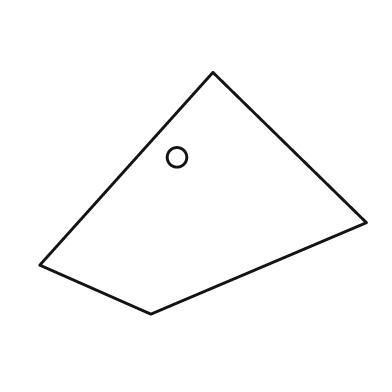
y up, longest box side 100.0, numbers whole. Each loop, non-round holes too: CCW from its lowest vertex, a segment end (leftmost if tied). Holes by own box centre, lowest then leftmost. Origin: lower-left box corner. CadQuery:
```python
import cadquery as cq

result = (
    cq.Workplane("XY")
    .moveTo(34.0, 0.0)
    .lineTo(100.0, 28.0)
    .lineTo(53.0, 74.0)
    .lineTo(0.0, 15.0)
    .close()
    .moveTo(42.0, 48.0)
    .circle(3.0)
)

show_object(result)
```